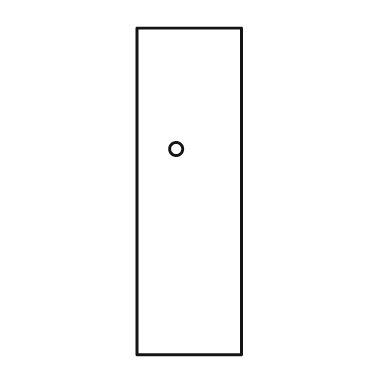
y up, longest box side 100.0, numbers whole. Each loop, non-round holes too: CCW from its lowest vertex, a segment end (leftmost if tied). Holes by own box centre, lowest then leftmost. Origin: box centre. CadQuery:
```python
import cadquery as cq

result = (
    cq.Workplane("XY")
    .moveTo(-16.0, -50.0)
    .lineTo(16.0, -50.0)
    .lineTo(16.0, 50.0)
    .lineTo(-16.0, 50.0)
    .close()
    .moveTo(-4.0, 13.0)
    .circle(2.0)
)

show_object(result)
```